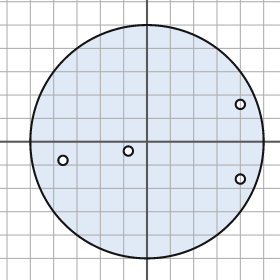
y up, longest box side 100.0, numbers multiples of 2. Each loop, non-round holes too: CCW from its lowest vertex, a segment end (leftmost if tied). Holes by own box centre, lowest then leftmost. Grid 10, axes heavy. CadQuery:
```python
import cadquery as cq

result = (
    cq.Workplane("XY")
    .moveTo(0.0, 0.0)
    .circle(50.0)
    .moveTo(40.0, -16.0)
    .circle(2.0)
    .moveTo(-36.0, -8.0)
    .circle(2.0)
    .moveTo(-8.0, -4.0)
    .circle(2.0)
    .moveTo(40.0, 16.0)
    .circle(2.0)
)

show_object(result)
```